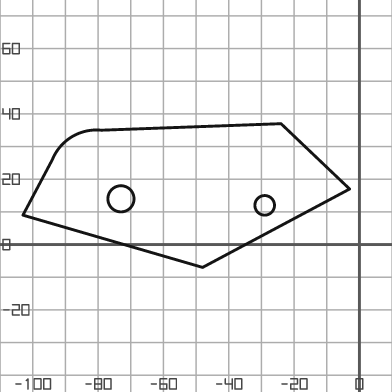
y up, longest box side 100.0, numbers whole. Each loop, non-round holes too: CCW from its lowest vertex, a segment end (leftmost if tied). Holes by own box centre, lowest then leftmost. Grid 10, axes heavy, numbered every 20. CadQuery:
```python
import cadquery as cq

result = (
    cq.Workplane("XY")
    .moveTo(-48.0, -7.0)
    .lineTo(-3.0, 17.0)
    .lineTo(-24.0, 37.0)
    .lineTo(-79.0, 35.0)
    .threePointArc((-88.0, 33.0), (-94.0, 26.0))
    .lineTo(-103.0, 9.0)
    .close()
    .moveTo(-29.0, 12.0)
    .circle(3.0)
    .moveTo(-73.0, 14.0)
    .circle(4.0)
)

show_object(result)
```